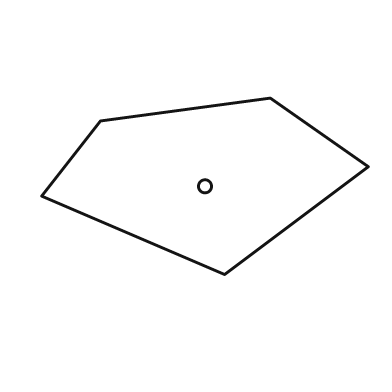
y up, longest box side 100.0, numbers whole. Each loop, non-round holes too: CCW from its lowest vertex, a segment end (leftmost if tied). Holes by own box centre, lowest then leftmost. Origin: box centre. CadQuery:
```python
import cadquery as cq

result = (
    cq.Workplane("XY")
    .moveTo(6.0, -27.0)
    .lineTo(50.0, 6.0)
    .lineTo(20.0, 27.0)
    .lineTo(-32.0, 20.0)
    .lineTo(-50.0, -3.0)
    .close()
    .moveTo(0.0, 0.0)
    .circle(2.0)
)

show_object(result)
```